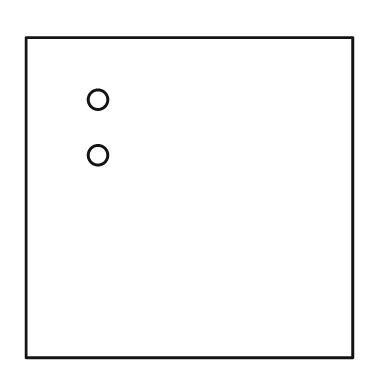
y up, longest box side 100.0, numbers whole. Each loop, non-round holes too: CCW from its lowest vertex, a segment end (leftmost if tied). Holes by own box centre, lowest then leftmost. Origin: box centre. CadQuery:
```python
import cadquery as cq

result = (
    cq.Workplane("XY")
    .moveTo(-50.0, -49.0)
    .lineTo(50.0, -49.0)
    .lineTo(50.0, 49.0)
    .lineTo(-50.0, 49.0)
    .close()
    .moveTo(-28.0, 13.0)
    .circle(3.0)
    .moveTo(-28.0, 30.0)
    .circle(3.0)
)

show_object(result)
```